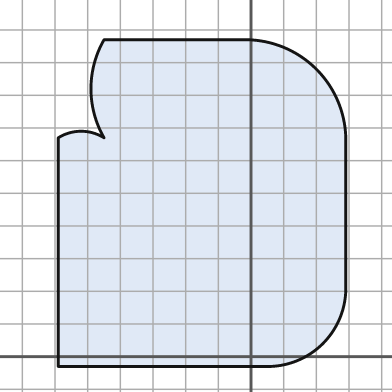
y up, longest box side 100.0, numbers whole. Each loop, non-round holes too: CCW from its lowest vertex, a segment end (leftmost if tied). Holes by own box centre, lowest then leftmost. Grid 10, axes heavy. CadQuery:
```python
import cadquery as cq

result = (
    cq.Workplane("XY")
    .moveTo(-59.0, -3.0)
    .lineTo(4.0, -3.0)
    .threePointArc((22.0, 4.0), (29.0, 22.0))
    .lineTo(29.0, 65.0)
    .threePointArc((20.0, 88.0), (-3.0, 97.0))
    .lineTo(-45.0, 97.0)
    .threePointArc((-49.0, 82.0), (-45.0, 67.0))
    .threePointArc((-52.0, 69.0), (-59.0, 67.0))
    .close()
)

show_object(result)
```